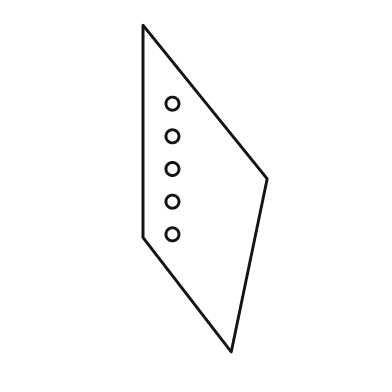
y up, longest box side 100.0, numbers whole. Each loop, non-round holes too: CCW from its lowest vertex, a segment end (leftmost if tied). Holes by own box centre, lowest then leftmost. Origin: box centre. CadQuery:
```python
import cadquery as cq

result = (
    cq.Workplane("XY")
    .moveTo(8.0, -50.0)
    .lineTo(19.0, 3.0)
    .lineTo(-19.0, 50.0)
    .lineTo(-19.0, -15.0)
    .close()
    .moveTo(-10.0, -14.0)
    .circle(2.0)
    .moveTo(-10.0, -4.0)
    .circle(2.0)
    .moveTo(-10.0, 6.0)
    .circle(2.0)
    .moveTo(-10.0, 16.0)
    .circle(2.0)
    .moveTo(-10.0, 26.0)
    .circle(2.0)
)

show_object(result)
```